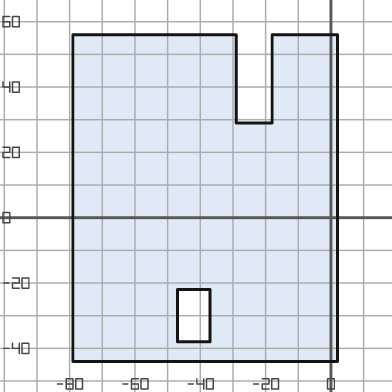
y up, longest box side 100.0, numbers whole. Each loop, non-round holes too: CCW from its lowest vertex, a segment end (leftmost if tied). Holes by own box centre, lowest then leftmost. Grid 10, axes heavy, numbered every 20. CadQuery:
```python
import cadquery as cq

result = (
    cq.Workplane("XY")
    .moveTo(-79.0, -44.0)
    .lineTo(2.0, -44.0)
    .lineTo(2.0, 56.0)
    .lineTo(-18.0, 56.0)
    .lineTo(-18.0, 29.0)
    .lineTo(-29.0, 29.0)
    .lineTo(-29.0, 56.0)
    .lineTo(-79.0, 56.0)
    .close()
    .moveTo(-47.0, -38.0)
    .lineTo(-37.0, -38.0)
    .lineTo(-37.0, -22.0)
    .lineTo(-47.0, -22.0)
    .close()
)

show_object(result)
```